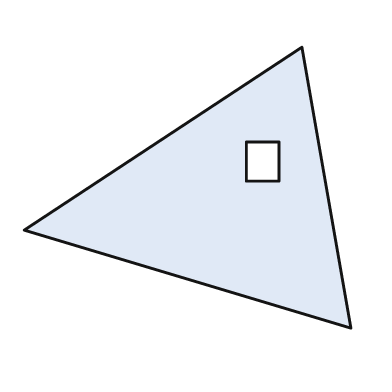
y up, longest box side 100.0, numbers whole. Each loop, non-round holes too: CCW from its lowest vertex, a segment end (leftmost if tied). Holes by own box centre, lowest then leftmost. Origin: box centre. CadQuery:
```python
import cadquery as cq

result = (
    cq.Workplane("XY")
    .moveTo(50.0, -43.0)
    .lineTo(35.0, 43.0)
    .lineTo(-50.0, -13.0)
    .close()
    .moveTo(18.0, 2.0)
    .lineTo(28.0, 2.0)
    .lineTo(28.0, 14.0)
    .lineTo(18.0, 14.0)
    .close()
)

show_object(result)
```